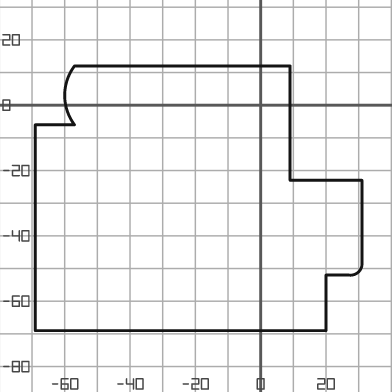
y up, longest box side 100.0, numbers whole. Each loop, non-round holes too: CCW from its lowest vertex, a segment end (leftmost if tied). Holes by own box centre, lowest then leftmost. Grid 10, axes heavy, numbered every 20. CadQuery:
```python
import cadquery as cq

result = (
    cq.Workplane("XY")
    .moveTo(-69.0, -69.0)
    .lineTo(20.0, -69.0)
    .lineTo(20.0, -52.0)
    .lineTo(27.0, -52.0)
    .threePointArc((30.0, -51.0), (31.0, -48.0))
    .lineTo(31.0, -23.0)
    .lineTo(9.0, -23.0)
    .lineTo(9.0, 12.0)
    .lineTo(-57.0, 12.0)
    .threePointArc((-60.0, 3.0), (-57.0, -6.0))
    .lineTo(-69.0, -6.0)
    .close()
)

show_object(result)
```